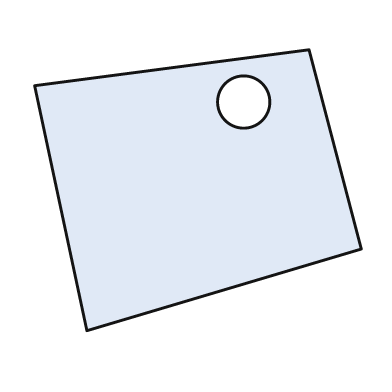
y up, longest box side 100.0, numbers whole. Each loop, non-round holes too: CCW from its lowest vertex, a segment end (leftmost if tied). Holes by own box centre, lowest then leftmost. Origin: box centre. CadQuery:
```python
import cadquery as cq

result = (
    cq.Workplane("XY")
    .moveTo(-34.0, -43.0)
    .lineTo(50.0, -18.0)
    .lineTo(34.0, 43.0)
    .lineTo(-50.0, 32.0)
    .close()
    .moveTo(14.0, 27.0)
    .circle(8.0)
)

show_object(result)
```